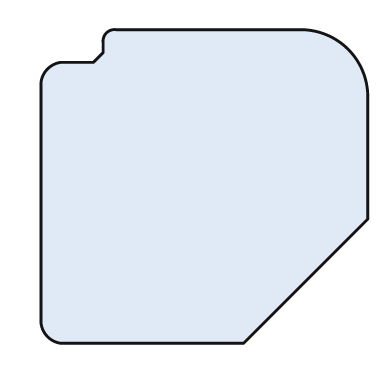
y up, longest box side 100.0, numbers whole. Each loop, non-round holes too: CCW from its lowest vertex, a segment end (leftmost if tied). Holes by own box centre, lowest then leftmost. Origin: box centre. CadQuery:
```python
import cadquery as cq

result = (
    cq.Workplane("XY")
    .moveTo(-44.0, -48.0)
    .lineTo(12.0, -48.0)
    .lineTo(50.0, -10.0)
    .lineTo(50.0, 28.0)
    .threePointArc((44.0, 42.0), (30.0, 48.0))
    .lineTo(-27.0, 48.0)
    .threePointArc((-30.0, 47.0), (-31.0, 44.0))
    .lineTo(-31.0, 41.0)
    .lineTo(-34.0, 38.0)
    .lineTo(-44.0, 38.0)
    .threePointArc((-48.0, 36.0), (-50.0, 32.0))
    .lineTo(-50.0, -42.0)
    .threePointArc((-48.0, -46.0), (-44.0, -48.0))
    .close()
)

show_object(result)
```